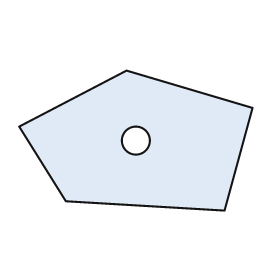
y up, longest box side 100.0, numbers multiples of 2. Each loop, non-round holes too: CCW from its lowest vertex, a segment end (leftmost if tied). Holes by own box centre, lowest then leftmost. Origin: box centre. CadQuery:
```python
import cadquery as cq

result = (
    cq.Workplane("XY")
    .moveTo(38.0, -30.0)
    .lineTo(50.0, 14.0)
    .lineTo(-4.0, 30.0)
    .lineTo(-50.0, 6.0)
    .lineTo(-30.0, -26.0)
    .close()
    .moveTo(0.0, 0.0)
    .circle(6.0)
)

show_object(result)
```